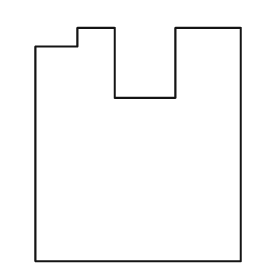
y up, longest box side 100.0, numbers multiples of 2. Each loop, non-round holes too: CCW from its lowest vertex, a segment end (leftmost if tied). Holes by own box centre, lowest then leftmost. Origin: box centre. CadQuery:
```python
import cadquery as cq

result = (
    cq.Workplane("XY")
    .moveTo(-44.0, -50.0)
    .lineTo(44.0, -50.0)
    .lineTo(44.0, 50.0)
    .lineTo(16.0, 50.0)
    .lineTo(16.0, 20.0)
    .lineTo(-10.0, 20.0)
    .lineTo(-10.0, 50.0)
    .lineTo(-26.0, 50.0)
    .lineTo(-26.0, 42.0)
    .lineTo(-44.0, 42.0)
    .close()
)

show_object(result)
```